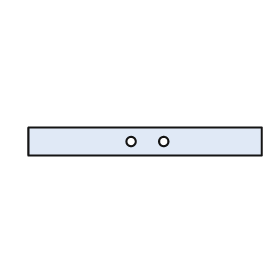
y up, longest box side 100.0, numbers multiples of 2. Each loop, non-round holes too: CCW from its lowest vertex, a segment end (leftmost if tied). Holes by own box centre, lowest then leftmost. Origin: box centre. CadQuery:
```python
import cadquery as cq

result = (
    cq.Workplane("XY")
    .moveTo(-50.0, -6.0)
    .lineTo(50.0, -6.0)
    .lineTo(50.0, 6.0)
    .lineTo(-50.0, 6.0)
    .close()
    .moveTo(-6.0, 0.0)
    .circle(2.0)
    .moveTo(8.0, 0.0)
    .circle(2.0)
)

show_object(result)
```